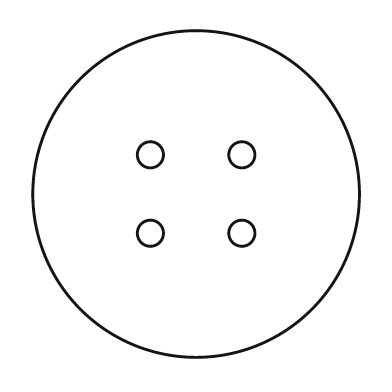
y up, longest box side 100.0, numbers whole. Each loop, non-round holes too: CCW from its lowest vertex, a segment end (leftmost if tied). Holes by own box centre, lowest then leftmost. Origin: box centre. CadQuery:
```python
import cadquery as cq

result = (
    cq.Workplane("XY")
    .moveTo(0.0, 0.0)
    .circle(50.0)
    .moveTo(-14.0, -12.0)
    .circle(4.0)
    .moveTo(14.0, -12.0)
    .circle(4.0)
    .moveTo(-14.0, 12.0)
    .circle(4.0)
    .moveTo(14.0, 12.0)
    .circle(4.0)
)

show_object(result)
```